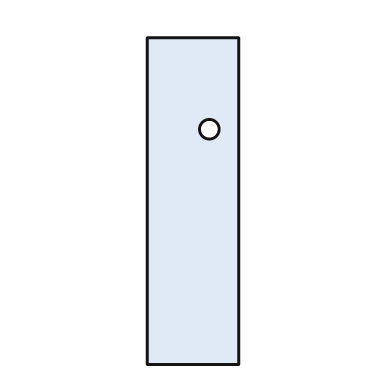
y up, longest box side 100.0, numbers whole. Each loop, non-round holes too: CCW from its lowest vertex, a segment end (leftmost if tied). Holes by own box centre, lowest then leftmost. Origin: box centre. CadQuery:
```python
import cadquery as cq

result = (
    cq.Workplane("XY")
    .moveTo(-14.0, -50.0)
    .lineTo(14.0, -50.0)
    .lineTo(14.0, 50.0)
    .lineTo(-14.0, 50.0)
    .close()
    .moveTo(5.0, 22.0)
    .circle(3.0)
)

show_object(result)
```